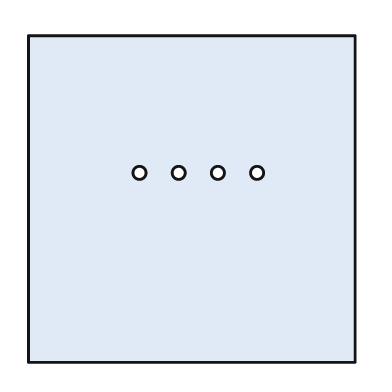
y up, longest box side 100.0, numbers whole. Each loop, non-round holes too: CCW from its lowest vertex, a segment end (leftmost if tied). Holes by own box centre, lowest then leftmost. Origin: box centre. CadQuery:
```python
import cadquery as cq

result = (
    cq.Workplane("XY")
    .moveTo(-50.0, -50.0)
    .lineTo(50.0, -50.0)
    .lineTo(50.0, 50.0)
    .lineTo(-50.0, 50.0)
    .close()
    .moveTo(-16.0, 8.0)
    .circle(2.0)
    .moveTo(-4.0, 8.0)
    .circle(2.0)
    .moveTo(8.0, 8.0)
    .circle(2.0)
    .moveTo(20.0, 8.0)
    .circle(2.0)
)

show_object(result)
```